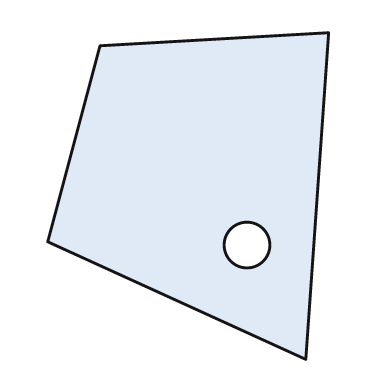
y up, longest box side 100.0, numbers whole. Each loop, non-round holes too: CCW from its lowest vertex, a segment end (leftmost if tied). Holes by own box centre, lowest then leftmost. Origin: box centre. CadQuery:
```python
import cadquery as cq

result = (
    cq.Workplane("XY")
    .moveTo(36.0, -50.0)
    .lineTo(43.0, 50.0)
    .lineTo(-27.0, 46.0)
    .lineTo(-43.0, -14.0)
    .close()
    .moveTo(18.0, -15.0)
    .circle(7.0)
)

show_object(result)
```